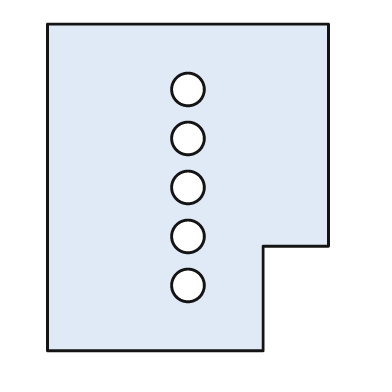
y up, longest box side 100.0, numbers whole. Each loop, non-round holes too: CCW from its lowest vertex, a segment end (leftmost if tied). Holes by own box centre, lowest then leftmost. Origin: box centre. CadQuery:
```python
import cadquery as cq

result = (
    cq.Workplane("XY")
    .moveTo(-43.0, -50.0)
    .lineTo(23.0, -50.0)
    .lineTo(23.0, -18.0)
    .lineTo(43.0, -18.0)
    .lineTo(43.0, 50.0)
    .lineTo(-43.0, 50.0)
    .close()
    .moveTo(0.0, -30.0)
    .circle(5.0)
    .moveTo(0.0, -15.0)
    .circle(5.0)
    .moveTo(0.0, 0.0)
    .circle(5.0)
    .moveTo(0.0, 15.0)
    .circle(5.0)
    .moveTo(0.0, 30.0)
    .circle(5.0)
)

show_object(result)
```